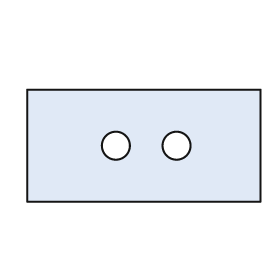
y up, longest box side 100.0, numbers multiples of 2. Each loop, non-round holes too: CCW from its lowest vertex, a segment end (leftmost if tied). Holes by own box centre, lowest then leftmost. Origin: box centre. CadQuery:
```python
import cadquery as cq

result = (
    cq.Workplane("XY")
    .moveTo(-50.0, -24.0)
    .lineTo(50.0, -24.0)
    .lineTo(50.0, 24.0)
    .lineTo(-50.0, 24.0)
    .close()
    .moveTo(-12.0, 0.0)
    .circle(6.0)
    .moveTo(14.0, 0.0)
    .circle(6.0)
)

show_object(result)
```